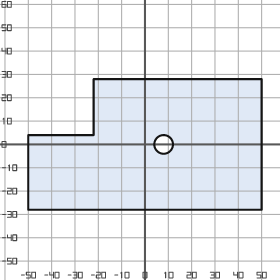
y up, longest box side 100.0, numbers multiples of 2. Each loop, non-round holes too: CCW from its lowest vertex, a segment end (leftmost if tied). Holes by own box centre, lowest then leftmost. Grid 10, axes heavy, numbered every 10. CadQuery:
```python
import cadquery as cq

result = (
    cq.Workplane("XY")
    .moveTo(-50.0, -28.0)
    .lineTo(50.0, -28.0)
    .lineTo(50.0, 28.0)
    .lineTo(-22.0, 28.0)
    .lineTo(-22.0, 4.0)
    .lineTo(-50.0, 4.0)
    .close()
    .moveTo(8.0, 0.0)
    .circle(4.0)
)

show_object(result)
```